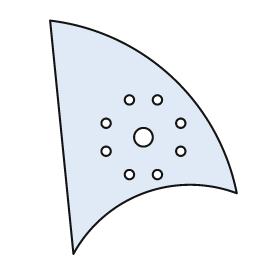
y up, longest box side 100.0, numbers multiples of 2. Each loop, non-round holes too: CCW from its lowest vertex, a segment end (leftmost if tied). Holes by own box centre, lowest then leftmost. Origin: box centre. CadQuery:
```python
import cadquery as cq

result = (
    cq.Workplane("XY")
    .moveTo(-30.0, -50.0)
    .threePointArc((0.0, -24.0), (40.0, -24.0))
    .threePointArc((12.0, 26.0), (-40.0, 50.0))
    .close()
    .moveTo(-6.0, -16.0)
    .circle(2.0)
    .moveTo(6.0, -16.0)
    .circle(2.0)
    .moveTo(-16.0, -6.0)
    .circle(2.0)
    .moveTo(16.0, -6.0)
    .circle(2.0)
    .moveTo(0.0, 0.0)
    .circle(4.0)
    .moveTo(-16.0, 6.0)
    .circle(2.0)
    .moveTo(16.0, 6.0)
    .circle(2.0)
    .moveTo(-6.0, 16.0)
    .circle(2.0)
    .moveTo(6.0, 16.0)
    .circle(2.0)
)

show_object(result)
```